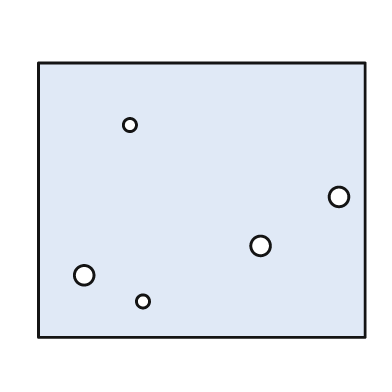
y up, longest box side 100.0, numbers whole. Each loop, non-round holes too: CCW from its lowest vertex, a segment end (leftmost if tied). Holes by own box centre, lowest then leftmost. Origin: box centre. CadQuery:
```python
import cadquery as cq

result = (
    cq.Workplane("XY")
    .moveTo(-50.0, -42.0)
    .lineTo(50.0, -42.0)
    .lineTo(50.0, 42.0)
    .lineTo(-50.0, 42.0)
    .close()
    .moveTo(-18.0, -31.0)
    .circle(2.0)
    .moveTo(-36.0, -23.0)
    .circle(3.0)
    .moveTo(18.0, -14.0)
    .circle(3.0)
    .moveTo(42.0, 1.0)
    .circle(3.0)
    .moveTo(-22.0, 23.0)
    .circle(2.0)
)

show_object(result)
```